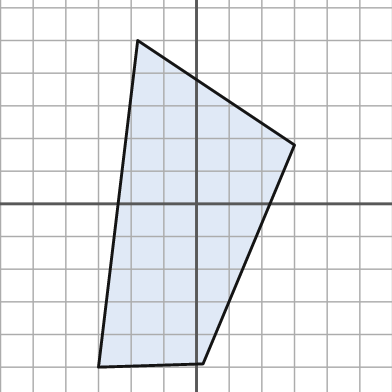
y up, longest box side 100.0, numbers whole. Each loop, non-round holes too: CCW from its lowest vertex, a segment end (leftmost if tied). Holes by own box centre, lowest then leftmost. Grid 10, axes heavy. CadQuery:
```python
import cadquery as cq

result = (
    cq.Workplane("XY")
    .moveTo(-30.0, -50.0)
    .lineTo(2.0, -49.0)
    .lineTo(30.0, 18.0)
    .lineTo(-18.0, 50.0)
    .close()
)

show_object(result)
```